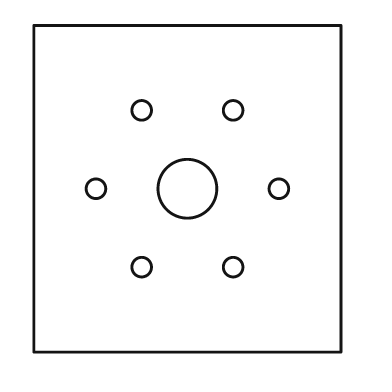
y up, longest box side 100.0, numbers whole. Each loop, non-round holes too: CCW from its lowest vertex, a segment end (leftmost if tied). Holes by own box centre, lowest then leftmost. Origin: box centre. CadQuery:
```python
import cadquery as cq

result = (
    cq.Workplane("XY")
    .moveTo(-47.0, -50.0)
    .lineTo(47.0, -50.0)
    .lineTo(47.0, 50.0)
    .lineTo(-47.0, 50.0)
    .close()
    .moveTo(-14.0, -24.0)
    .circle(3.0)
    .moveTo(14.0, -24.0)
    .circle(3.0)
    .moveTo(-28.0, 0.0)
    .circle(3.0)
    .moveTo(0.0, 0.0)
    .circle(9.0)
    .moveTo(28.0, 0.0)
    .circle(3.0)
    .moveTo(-14.0, 24.0)
    .circle(3.0)
    .moveTo(14.0, 24.0)
    .circle(3.0)
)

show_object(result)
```